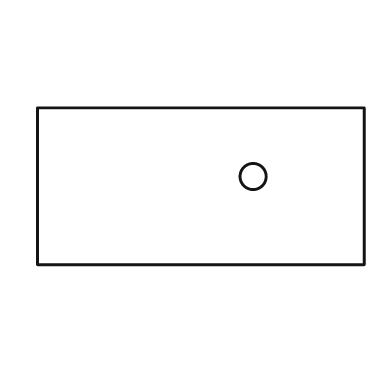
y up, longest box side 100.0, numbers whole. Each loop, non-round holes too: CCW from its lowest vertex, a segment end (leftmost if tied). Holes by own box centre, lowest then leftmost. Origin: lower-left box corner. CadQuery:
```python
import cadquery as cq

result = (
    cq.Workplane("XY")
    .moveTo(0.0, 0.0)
    .lineTo(100.0, 0.0)
    .lineTo(100.0, 48.0)
    .lineTo(0.0, 48.0)
    .close()
    .moveTo(66.0, 27.0)
    .circle(4.0)
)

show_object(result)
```